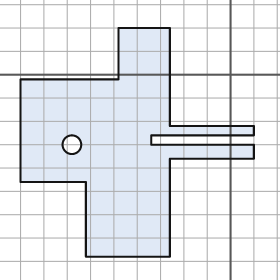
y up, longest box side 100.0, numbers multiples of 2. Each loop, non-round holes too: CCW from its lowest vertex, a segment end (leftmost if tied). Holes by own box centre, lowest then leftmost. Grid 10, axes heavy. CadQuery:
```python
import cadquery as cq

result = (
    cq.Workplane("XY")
    .moveTo(-62.0, -78.0)
    .lineTo(-26.0, -78.0)
    .lineTo(-26.0, -36.0)
    .lineTo(10.0, -36.0)
    .lineTo(10.0, -30.0)
    .lineTo(-34.0, -30.0)
    .lineTo(-34.0, -26.0)
    .lineTo(10.0, -26.0)
    .lineTo(10.0, -22.0)
    .lineTo(-26.0, -22.0)
    .lineTo(-26.0, 20.0)
    .lineTo(-48.0, 20.0)
    .lineTo(-48.0, -2.0)
    .lineTo(-90.0, -2.0)
    .lineTo(-90.0, -46.0)
    .lineTo(-62.0, -46.0)
    .close()
    .moveTo(-68.0, -30.0)
    .circle(4.0)
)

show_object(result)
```